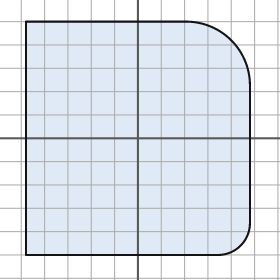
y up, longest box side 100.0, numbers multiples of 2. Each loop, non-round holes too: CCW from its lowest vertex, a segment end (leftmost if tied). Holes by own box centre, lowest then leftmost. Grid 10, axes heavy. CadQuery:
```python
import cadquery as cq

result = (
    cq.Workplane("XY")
    .moveTo(-48.0, -50.0)
    .lineTo(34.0, -50.0)
    .threePointArc((44.0, -46.0), (48.0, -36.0))
    .lineTo(48.0, 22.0)
    .threePointArc((40.0, 42.0), (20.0, 50.0))
    .lineTo(-48.0, 50.0)
    .close()
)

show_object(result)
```